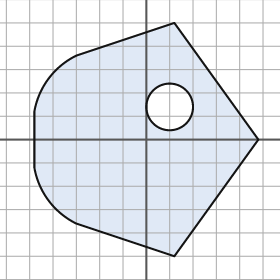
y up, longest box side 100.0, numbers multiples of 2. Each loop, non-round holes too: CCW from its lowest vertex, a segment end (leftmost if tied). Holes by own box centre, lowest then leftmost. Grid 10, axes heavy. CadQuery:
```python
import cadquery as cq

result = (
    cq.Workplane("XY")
    .moveTo(12.0, -50.0)
    .lineTo(48.0, 0.0)
    .lineTo(12.0, 50.0)
    .lineTo(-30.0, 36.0)
    .threePointArc((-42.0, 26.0), (-48.0, 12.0))
    .lineTo(-48.0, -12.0)
    .threePointArc((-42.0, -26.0), (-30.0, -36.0))
    .close()
    .moveTo(10.0, 14.0)
    .circle(10.0)
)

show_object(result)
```